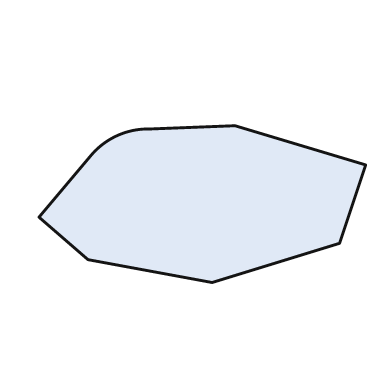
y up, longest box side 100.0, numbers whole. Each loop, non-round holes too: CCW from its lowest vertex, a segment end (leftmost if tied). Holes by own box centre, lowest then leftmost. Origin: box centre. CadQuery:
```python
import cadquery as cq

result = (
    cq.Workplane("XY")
    .moveTo(3.0, -24.0)
    .lineTo(42.0, -12.0)
    .lineTo(50.0, 12.0)
    .lineTo(10.0, 24.0)
    .lineTo(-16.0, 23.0)
    .threePointArc((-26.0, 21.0), (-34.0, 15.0))
    .lineTo(-50.0, -4.0)
    .lineTo(-35.0, -17.0)
    .close()
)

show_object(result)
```